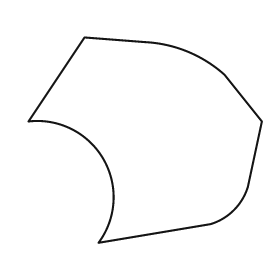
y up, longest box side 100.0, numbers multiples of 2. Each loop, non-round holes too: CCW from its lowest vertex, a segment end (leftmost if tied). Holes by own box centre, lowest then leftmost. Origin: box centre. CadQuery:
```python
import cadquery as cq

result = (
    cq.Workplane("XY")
    .moveTo(-20.0, -44.0)
    .lineTo(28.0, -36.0)
    .threePointArc((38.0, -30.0), (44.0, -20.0))
    .lineTo(50.0, 8.0)
    .lineTo(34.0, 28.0)
    .threePointArc((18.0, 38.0), (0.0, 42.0))
    .lineTo(-26.0, 44.0)
    .lineTo(-50.0, 8.0)
    .threePointArc((-18.0, -8.0), (-20.0, -44.0))
    .close()
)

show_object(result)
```